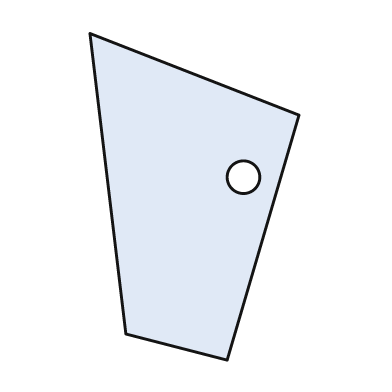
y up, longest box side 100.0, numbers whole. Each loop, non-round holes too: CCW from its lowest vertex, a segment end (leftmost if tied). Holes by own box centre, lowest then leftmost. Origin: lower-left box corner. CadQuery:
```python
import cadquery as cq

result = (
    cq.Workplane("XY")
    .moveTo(42.0, 0.0)
    .lineTo(64.0, 75.0)
    .lineTo(0.0, 100.0)
    .lineTo(11.0, 8.0)
    .close()
    .moveTo(47.0, 56.0)
    .circle(5.0)
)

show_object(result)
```